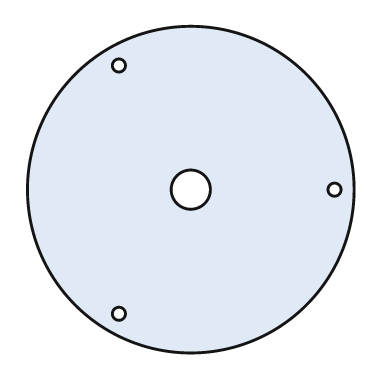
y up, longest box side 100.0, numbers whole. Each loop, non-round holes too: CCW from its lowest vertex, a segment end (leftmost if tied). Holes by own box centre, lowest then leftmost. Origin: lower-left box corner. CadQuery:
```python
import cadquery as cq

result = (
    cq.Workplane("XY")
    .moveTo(50.0, 50.0)
    .circle(50.0)
    .moveTo(28.0, 12.0)
    .circle(2.0)
    .moveTo(50.0, 50.0)
    .circle(6.0)
    .moveTo(94.0, 50.0)
    .circle(2.0)
    .moveTo(28.0, 88.0)
    .circle(2.0)
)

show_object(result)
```